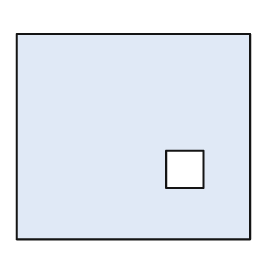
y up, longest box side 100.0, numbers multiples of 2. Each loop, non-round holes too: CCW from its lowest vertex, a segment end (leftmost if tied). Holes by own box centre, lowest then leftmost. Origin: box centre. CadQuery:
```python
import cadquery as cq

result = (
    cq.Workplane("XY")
    .moveTo(-50.0, -44.0)
    .lineTo(50.0, -44.0)
    .lineTo(50.0, 44.0)
    .lineTo(-50.0, 44.0)
    .close()
    .moveTo(14.0, -22.0)
    .lineTo(30.0, -22.0)
    .lineTo(30.0, -6.0)
    .lineTo(14.0, -6.0)
    .close()
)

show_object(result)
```